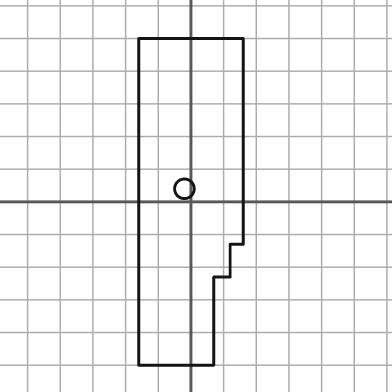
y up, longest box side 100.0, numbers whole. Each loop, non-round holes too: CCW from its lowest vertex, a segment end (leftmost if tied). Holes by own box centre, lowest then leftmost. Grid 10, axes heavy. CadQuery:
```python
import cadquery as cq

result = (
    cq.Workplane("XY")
    .moveTo(-16.0, -50.0)
    .lineTo(7.0, -50.0)
    .lineTo(7.0, -23.0)
    .lineTo(12.0, -23.0)
    .lineTo(12.0, -13.0)
    .lineTo(16.0, -13.0)
    .lineTo(16.0, 50.0)
    .lineTo(-16.0, 50.0)
    .close()
    .moveTo(-2.0, 4.0)
    .circle(3.0)
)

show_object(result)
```